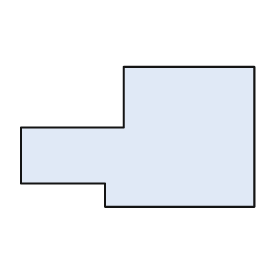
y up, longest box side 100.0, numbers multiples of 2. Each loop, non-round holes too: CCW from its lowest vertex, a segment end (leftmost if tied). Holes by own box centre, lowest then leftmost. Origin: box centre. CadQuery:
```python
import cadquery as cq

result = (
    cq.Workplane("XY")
    .moveTo(-14.0, -30.0)
    .lineTo(50.0, -30.0)
    .lineTo(50.0, 30.0)
    .lineTo(-6.0, 30.0)
    .lineTo(-6.0, 4.0)
    .lineTo(-50.0, 4.0)
    .lineTo(-50.0, -20.0)
    .lineTo(-14.0, -20.0)
    .close()
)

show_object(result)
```